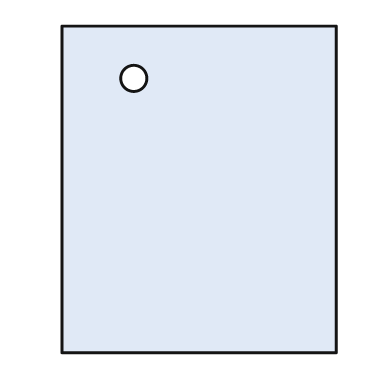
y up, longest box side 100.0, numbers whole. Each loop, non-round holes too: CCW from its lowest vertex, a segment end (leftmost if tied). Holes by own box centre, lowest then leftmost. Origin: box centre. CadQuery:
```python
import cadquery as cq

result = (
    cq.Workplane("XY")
    .moveTo(-42.0, -50.0)
    .lineTo(42.0, -50.0)
    .lineTo(42.0, 50.0)
    .lineTo(-42.0, 50.0)
    .close()
    .moveTo(-20.0, 34.0)
    .circle(4.0)
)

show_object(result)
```